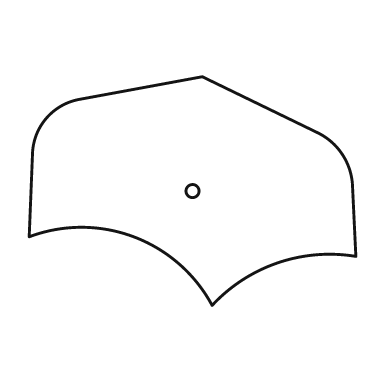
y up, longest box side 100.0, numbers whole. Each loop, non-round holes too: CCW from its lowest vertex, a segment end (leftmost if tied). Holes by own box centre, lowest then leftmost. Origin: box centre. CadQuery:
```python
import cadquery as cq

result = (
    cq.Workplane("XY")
    .moveTo(6.0, -35.0)
    .threePointArc((26.0, -22.0), (50.0, -20.0))
    .lineTo(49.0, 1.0)
    .threePointArc((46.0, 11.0), (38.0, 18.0))
    .lineTo(3.0, 35.0)
    .lineTo(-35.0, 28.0)
    .threePointArc((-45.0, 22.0), (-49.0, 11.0))
    .lineTo(-50.0, -14.0)
    .threePointArc((-18.0, -14.0), (6.0, -35.0))
    .close()
    .moveTo(0.0, 0.0)
    .circle(2.0)
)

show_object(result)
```